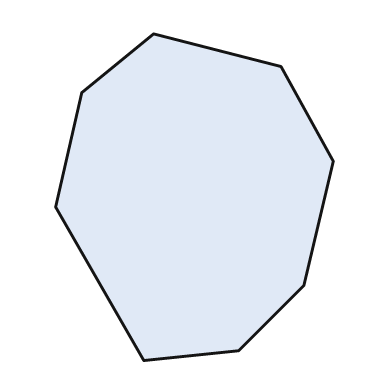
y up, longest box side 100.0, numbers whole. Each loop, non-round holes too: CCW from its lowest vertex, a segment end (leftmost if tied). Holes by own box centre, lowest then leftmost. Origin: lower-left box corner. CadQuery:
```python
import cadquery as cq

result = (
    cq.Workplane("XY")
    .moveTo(27.0, 0.0)
    .lineTo(56.0, 3.0)
    .lineTo(76.0, 23.0)
    .lineTo(85.0, 61.0)
    .lineTo(69.0, 90.0)
    .lineTo(30.0, 100.0)
    .lineTo(8.0, 82.0)
    .lineTo(0.0, 47.0)
    .close()
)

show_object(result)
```